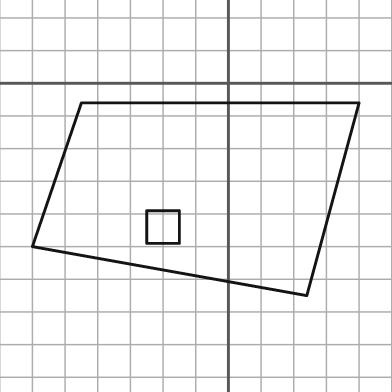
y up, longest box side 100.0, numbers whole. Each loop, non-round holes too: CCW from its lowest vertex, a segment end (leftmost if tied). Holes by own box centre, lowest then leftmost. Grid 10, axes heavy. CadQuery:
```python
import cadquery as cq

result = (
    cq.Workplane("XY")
    .moveTo(24.0, -65.0)
    .lineTo(40.0, -6.0)
    .lineTo(-45.0, -6.0)
    .lineTo(-60.0, -50.0)
    .close()
    .moveTo(-25.0, -49.0)
    .lineTo(-15.0, -49.0)
    .lineTo(-15.0, -39.0)
    .lineTo(-25.0, -39.0)
    .close()
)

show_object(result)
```